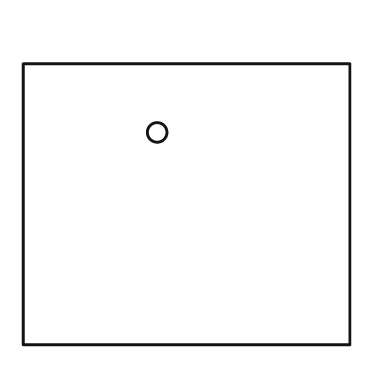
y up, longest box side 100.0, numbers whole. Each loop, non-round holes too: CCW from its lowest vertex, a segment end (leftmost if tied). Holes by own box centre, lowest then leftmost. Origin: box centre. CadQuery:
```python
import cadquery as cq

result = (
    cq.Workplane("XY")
    .moveTo(-50.0, -43.0)
    .lineTo(50.0, -43.0)
    .lineTo(50.0, 43.0)
    .lineTo(-50.0, 43.0)
    .close()
    .moveTo(-9.0, 22.0)
    .circle(3.0)
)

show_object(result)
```